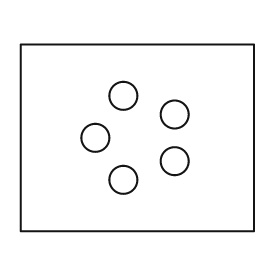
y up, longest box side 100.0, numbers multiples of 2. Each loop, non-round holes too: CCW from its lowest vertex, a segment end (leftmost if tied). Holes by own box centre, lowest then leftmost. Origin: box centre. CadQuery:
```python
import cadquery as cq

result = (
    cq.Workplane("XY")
    .moveTo(-50.0, -40.0)
    .lineTo(50.0, -40.0)
    .lineTo(50.0, 40.0)
    .lineTo(-50.0, 40.0)
    .close()
    .moveTo(-6.0, -18.0)
    .circle(6.0)
    .moveTo(16.0, -10.0)
    .circle(6.0)
    .moveTo(-18.0, 0.0)
    .circle(6.0)
    .moveTo(16.0, 10.0)
    .circle(6.0)
    .moveTo(-6.0, 18.0)
    .circle(6.0)
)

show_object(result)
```